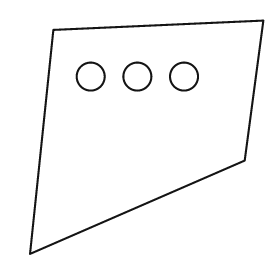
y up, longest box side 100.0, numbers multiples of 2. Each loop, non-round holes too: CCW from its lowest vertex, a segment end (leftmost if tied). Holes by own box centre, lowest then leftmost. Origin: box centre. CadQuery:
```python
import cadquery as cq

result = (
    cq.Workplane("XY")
    .moveTo(-50.0, -50.0)
    .lineTo(42.0, -10.0)
    .lineTo(50.0, 50.0)
    .lineTo(-40.0, 46.0)
    .close()
    .moveTo(-24.0, 26.0)
    .circle(6.0)
    .moveTo(-4.0, 26.0)
    .circle(6.0)
    .moveTo(16.0, 26.0)
    .circle(6.0)
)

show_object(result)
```